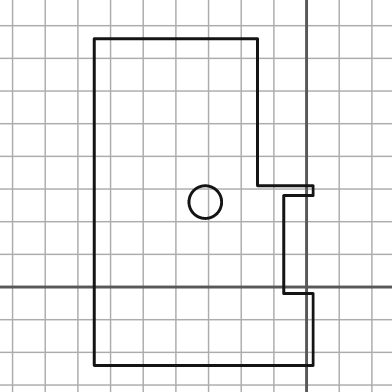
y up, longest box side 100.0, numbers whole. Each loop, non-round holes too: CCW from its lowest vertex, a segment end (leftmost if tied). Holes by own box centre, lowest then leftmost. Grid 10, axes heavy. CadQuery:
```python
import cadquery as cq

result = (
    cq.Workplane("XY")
    .moveTo(-65.0, -24.0)
    .lineTo(2.0, -24.0)
    .lineTo(2.0, -2.0)
    .lineTo(-7.0, -2.0)
    .lineTo(-7.0, 28.0)
    .lineTo(2.0, 28.0)
    .lineTo(2.0, 31.0)
    .lineTo(-15.0, 31.0)
    .lineTo(-15.0, 76.0)
    .lineTo(-65.0, 76.0)
    .close()
    .moveTo(-31.0, 26.0)
    .circle(5.0)
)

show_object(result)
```